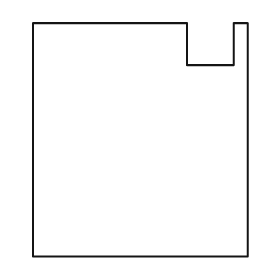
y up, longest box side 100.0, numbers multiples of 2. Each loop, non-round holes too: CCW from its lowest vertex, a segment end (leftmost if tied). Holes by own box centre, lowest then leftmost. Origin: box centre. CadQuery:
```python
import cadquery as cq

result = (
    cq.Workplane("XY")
    .moveTo(-46.0, -50.0)
    .lineTo(46.0, -50.0)
    .lineTo(46.0, 50.0)
    .lineTo(40.0, 50.0)
    .lineTo(40.0, 32.0)
    .lineTo(20.0, 32.0)
    .lineTo(20.0, 50.0)
    .lineTo(-46.0, 50.0)
    .close()
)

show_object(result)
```